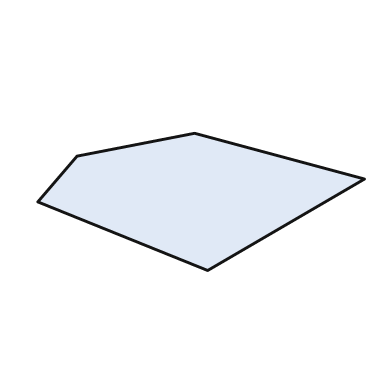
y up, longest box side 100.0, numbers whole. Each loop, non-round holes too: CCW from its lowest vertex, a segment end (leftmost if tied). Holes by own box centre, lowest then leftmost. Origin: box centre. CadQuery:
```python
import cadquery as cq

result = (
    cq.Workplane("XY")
    .moveTo(2.0, -21.0)
    .lineTo(50.0, 7.0)
    .lineTo(-2.0, 21.0)
    .lineTo(-38.0, 14.0)
    .lineTo(-50.0, 0.0)
    .close()
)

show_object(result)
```